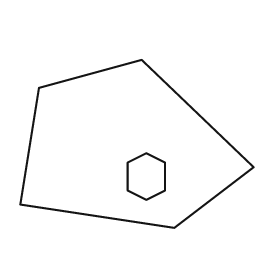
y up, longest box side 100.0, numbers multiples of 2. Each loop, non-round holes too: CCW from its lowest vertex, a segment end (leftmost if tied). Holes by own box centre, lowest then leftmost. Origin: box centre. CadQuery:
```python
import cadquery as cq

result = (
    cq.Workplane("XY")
    .moveTo(16.0, -36.0)
    .lineTo(50.0, -10.0)
    .lineTo(2.0, 36.0)
    .lineTo(-42.0, 24.0)
    .lineTo(-50.0, -26.0)
    .close()
    .moveTo(4.0, -24.0)
    .lineTo(12.0, -20.0)
    .lineTo(12.0, -8.0)
    .lineTo(4.0, -4.0)
    .lineTo(-4.0, -8.0)
    .lineTo(-4.0, -20.0)
    .close()
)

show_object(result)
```